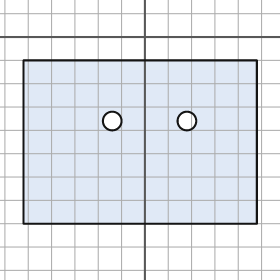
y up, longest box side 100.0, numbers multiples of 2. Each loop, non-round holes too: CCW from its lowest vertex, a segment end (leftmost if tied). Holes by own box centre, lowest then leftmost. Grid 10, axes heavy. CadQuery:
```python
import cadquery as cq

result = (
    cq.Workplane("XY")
    .moveTo(-52.0, -80.0)
    .lineTo(48.0, -80.0)
    .lineTo(48.0, -10.0)
    .lineTo(-52.0, -10.0)
    .close()
    .moveTo(-14.0, -36.0)
    .circle(4.0)
    .moveTo(18.0, -36.0)
    .circle(4.0)
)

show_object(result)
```